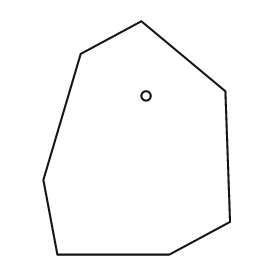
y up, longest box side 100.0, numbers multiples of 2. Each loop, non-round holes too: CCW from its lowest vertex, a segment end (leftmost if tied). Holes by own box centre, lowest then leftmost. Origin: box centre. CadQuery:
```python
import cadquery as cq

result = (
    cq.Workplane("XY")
    .moveTo(-34.0, -50.0)
    .lineTo(14.0, -50.0)
    .lineTo(40.0, -36.0)
    .lineTo(38.0, 20.0)
    .lineTo(2.0, 50.0)
    .lineTo(-24.0, 36.0)
    .lineTo(-40.0, -18.0)
    .close()
    .moveTo(4.0, 18.0)
    .circle(2.0)
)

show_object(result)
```